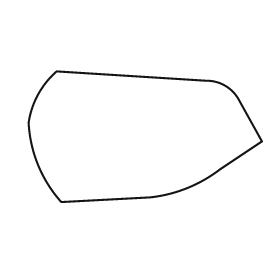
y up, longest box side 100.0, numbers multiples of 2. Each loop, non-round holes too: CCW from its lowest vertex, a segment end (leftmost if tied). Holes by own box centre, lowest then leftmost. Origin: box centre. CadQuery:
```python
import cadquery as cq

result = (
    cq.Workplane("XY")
    .moveTo(-36.0, -28.0)
    .lineTo(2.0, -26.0)
    .threePointArc((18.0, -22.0), (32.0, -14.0))
    .lineTo(50.0, -2.0)
    .lineTo(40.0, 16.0)
    .threePointArc((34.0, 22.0), (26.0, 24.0))
    .lineTo(-38.0, 28.0)
    .threePointArc((-46.0, 18.0), (-50.0, 6.0))
    .threePointArc((-46.0, -12.0), (-36.0, -28.0))
    .close()
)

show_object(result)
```